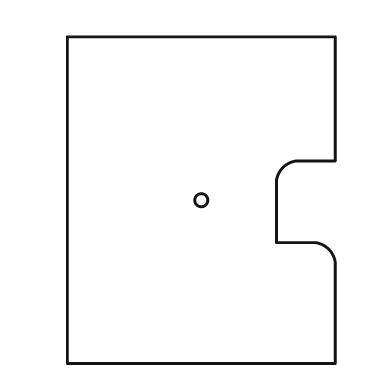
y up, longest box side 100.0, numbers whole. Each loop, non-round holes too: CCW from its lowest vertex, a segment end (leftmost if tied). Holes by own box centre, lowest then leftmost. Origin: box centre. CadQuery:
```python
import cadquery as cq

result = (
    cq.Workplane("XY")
    .moveTo(-41.0, -50.0)
    .lineTo(41.0, -50.0)
    .lineTo(41.0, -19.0)
    .threePointArc((39.0, -15.0), (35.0, -13.0))
    .lineTo(23.0, -13.0)
    .lineTo(23.0, 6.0)
    .threePointArc((25.0, 10.0), (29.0, 12.0))
    .lineTo(41.0, 12.0)
    .lineTo(41.0, 50.0)
    .lineTo(-41.0, 50.0)
    .close()
    .moveTo(0.0, 0.0)
    .circle(2.0)
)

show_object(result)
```